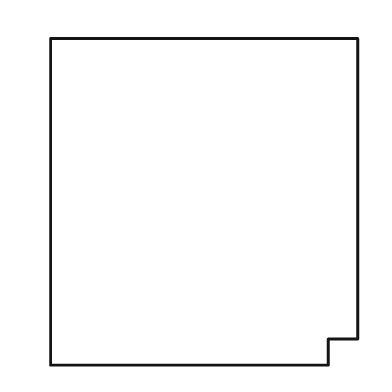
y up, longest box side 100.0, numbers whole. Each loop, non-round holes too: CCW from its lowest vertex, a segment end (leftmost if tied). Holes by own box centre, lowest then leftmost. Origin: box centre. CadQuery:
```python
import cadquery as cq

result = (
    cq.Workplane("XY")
    .moveTo(-47.0, -50.0)
    .lineTo(38.0, -50.0)
    .lineTo(38.0, -42.0)
    .lineTo(47.0, -42.0)
    .lineTo(47.0, 50.0)
    .lineTo(-47.0, 50.0)
    .close()
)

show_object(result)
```